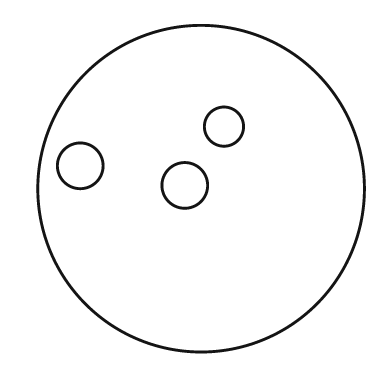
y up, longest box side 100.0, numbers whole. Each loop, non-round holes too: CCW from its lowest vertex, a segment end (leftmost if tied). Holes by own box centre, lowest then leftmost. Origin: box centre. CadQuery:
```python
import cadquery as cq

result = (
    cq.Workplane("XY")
    .moveTo(0.0, 0.0)
    .circle(50.0)
    .moveTo(-5.0, 1.0)
    .circle(7.0)
    .moveTo(-37.0, 7.0)
    .circle(7.0)
    .moveTo(7.0, 19.0)
    .circle(6.0)
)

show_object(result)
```